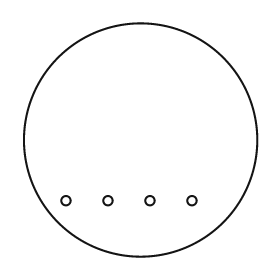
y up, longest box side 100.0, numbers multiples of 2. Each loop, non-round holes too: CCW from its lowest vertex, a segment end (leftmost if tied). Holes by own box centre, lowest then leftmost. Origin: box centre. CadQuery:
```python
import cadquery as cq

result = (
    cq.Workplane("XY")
    .moveTo(0.0, 0.0)
    .circle(50.0)
    .moveTo(-32.0, -26.0)
    .circle(2.0)
    .moveTo(-14.0, -26.0)
    .circle(2.0)
    .moveTo(4.0, -26.0)
    .circle(2.0)
    .moveTo(22.0, -26.0)
    .circle(2.0)
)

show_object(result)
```